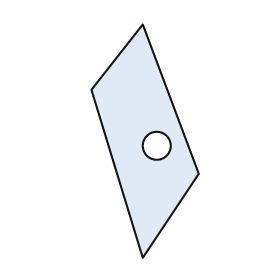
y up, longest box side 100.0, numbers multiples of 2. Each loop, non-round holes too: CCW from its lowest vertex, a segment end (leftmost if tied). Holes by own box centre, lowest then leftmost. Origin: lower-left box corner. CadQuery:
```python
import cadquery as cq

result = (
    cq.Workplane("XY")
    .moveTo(22.0, 0.0)
    .lineTo(46.0, 36.0)
    .lineTo(22.0, 100.0)
    .lineTo(0.0, 72.0)
    .close()
    .moveTo(28.0, 48.0)
    .circle(6.0)
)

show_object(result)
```